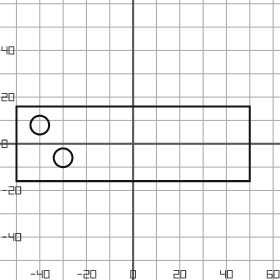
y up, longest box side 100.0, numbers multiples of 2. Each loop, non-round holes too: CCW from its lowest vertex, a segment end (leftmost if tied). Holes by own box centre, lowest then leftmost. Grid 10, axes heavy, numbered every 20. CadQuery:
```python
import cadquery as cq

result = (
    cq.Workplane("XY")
    .moveTo(-50.0, -16.0)
    .lineTo(50.0, -16.0)
    .lineTo(50.0, 16.0)
    .lineTo(-50.0, 16.0)
    .close()
    .moveTo(-30.0, -6.0)
    .circle(4.0)
    .moveTo(-40.0, 8.0)
    .circle(4.0)
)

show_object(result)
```